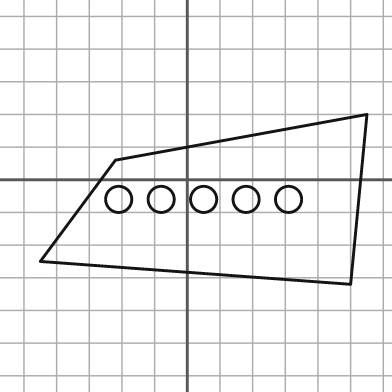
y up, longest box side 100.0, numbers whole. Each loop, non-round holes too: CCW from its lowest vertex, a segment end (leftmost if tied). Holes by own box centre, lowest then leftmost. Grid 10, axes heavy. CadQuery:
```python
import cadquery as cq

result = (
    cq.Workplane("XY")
    .moveTo(50.0, -32.0)
    .lineTo(55.0, 20.0)
    .lineTo(-22.0, 6.0)
    .lineTo(-45.0, -25.0)
    .close()
    .moveTo(-21.0, -6.0)
    .circle(4.0)
    .moveTo(-8.0, -6.0)
    .circle(4.0)
    .moveTo(5.0, -6.0)
    .circle(4.0)
    .moveTo(18.0, -6.0)
    .circle(4.0)
    .moveTo(31.0, -6.0)
    .circle(4.0)
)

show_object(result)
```